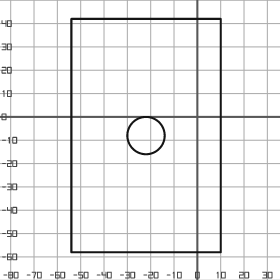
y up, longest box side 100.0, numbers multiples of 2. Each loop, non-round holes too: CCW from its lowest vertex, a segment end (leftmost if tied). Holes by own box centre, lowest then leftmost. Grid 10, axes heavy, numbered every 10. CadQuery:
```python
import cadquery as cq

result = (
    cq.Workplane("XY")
    .moveTo(-54.0, -58.0)
    .lineTo(10.0, -58.0)
    .lineTo(10.0, 42.0)
    .lineTo(-54.0, 42.0)
    .close()
    .moveTo(-22.0, -8.0)
    .circle(8.0)
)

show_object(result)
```